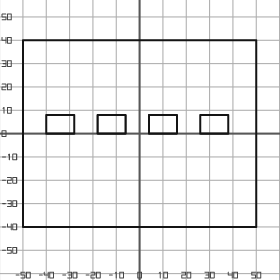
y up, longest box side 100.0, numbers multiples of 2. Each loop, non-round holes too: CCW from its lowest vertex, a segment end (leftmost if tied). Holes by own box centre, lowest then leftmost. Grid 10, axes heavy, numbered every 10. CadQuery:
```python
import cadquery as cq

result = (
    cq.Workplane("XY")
    .moveTo(-50.0, -40.0)
    .lineTo(50.0, -40.0)
    .lineTo(50.0, 40.0)
    .lineTo(-50.0, 40.0)
    .close()
    .moveTo(-40.0, 0.0)
    .lineTo(-28.0, 0.0)
    .lineTo(-28.0, 8.0)
    .lineTo(-40.0, 8.0)
    .close()
    .moveTo(-18.0, 0.0)
    .lineTo(-6.0, 0.0)
    .lineTo(-6.0, 8.0)
    .lineTo(-18.0, 8.0)
    .close()
    .moveTo(4.0, 0.0)
    .lineTo(16.0, 0.0)
    .lineTo(16.0, 8.0)
    .lineTo(4.0, 8.0)
    .close()
    .moveTo(26.0, 0.0)
    .lineTo(38.0, 0.0)
    .lineTo(38.0, 8.0)
    .lineTo(26.0, 8.0)
    .close()
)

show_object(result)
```